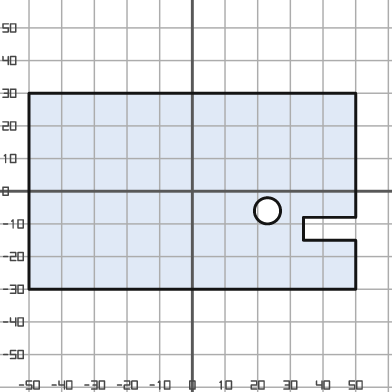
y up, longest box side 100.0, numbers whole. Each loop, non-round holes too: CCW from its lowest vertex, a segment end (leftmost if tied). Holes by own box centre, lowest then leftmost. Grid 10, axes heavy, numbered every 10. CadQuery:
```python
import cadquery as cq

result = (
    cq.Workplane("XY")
    .moveTo(-50.0, -30.0)
    .lineTo(50.0, -30.0)
    .lineTo(50.0, -15.0)
    .lineTo(34.0, -15.0)
    .lineTo(34.0, -8.0)
    .lineTo(50.0, -8.0)
    .lineTo(50.0, 30.0)
    .lineTo(-50.0, 30.0)
    .close()
    .moveTo(23.0, -6.0)
    .circle(4.0)
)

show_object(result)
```